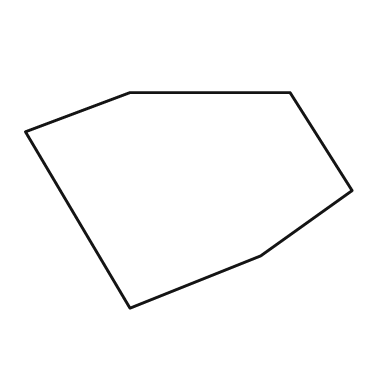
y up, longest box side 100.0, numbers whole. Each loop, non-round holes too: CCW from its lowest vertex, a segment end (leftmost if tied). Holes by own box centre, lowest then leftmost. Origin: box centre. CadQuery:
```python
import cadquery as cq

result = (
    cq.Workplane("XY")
    .moveTo(-18.0, -33.0)
    .lineTo(22.0, -17.0)
    .lineTo(50.0, 3.0)
    .lineTo(31.0, 33.0)
    .lineTo(-18.0, 33.0)
    .lineTo(-50.0, 21.0)
    .close()
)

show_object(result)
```